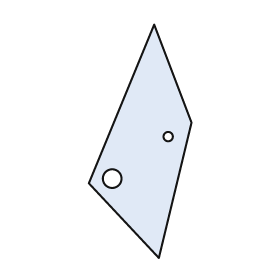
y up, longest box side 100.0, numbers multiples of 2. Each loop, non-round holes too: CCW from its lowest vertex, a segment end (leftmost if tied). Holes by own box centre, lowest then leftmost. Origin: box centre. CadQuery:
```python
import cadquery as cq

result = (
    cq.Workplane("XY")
    .moveTo(8.0, -50.0)
    .lineTo(22.0, 8.0)
    .lineTo(6.0, 50.0)
    .lineTo(-22.0, -18.0)
    .close()
    .moveTo(-12.0, -16.0)
    .circle(4.0)
    .moveTo(12.0, 2.0)
    .circle(2.0)
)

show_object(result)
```